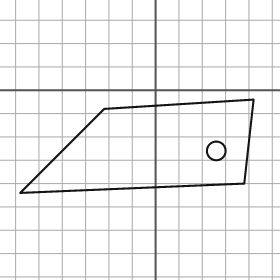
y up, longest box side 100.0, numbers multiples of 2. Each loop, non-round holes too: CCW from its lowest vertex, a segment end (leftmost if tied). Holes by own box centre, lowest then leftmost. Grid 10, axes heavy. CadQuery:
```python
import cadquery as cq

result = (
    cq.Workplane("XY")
    .moveTo(-58.0, -44.0)
    .lineTo(38.0, -40.0)
    .lineTo(42.0, -4.0)
    .lineTo(-22.0, -8.0)
    .close()
    .moveTo(26.0, -26.0)
    .circle(4.0)
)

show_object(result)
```